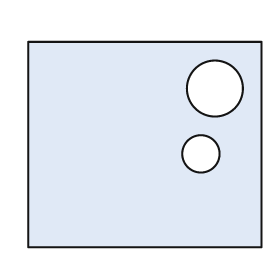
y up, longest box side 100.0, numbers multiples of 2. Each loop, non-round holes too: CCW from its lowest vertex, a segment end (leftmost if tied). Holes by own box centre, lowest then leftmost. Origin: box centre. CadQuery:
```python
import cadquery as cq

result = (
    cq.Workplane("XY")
    .moveTo(-50.0, -44.0)
    .lineTo(50.0, -44.0)
    .lineTo(50.0, 44.0)
    .lineTo(-50.0, 44.0)
    .close()
    .moveTo(24.0, -4.0)
    .circle(8.0)
    .moveTo(30.0, 24.0)
    .circle(12.0)
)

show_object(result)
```